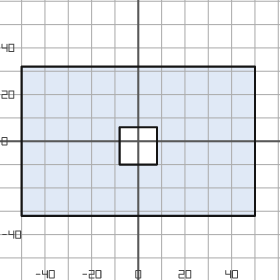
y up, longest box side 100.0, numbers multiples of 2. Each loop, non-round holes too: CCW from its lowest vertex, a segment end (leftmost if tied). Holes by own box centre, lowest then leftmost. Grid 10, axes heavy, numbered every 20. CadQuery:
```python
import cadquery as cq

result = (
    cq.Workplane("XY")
    .moveTo(-50.0, -32.0)
    .lineTo(50.0, -32.0)
    .lineTo(50.0, 32.0)
    .lineTo(-50.0, 32.0)
    .close()
    .moveTo(-8.0, -10.0)
    .lineTo(8.0, -10.0)
    .lineTo(8.0, 6.0)
    .lineTo(-8.0, 6.0)
    .close()
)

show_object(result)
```